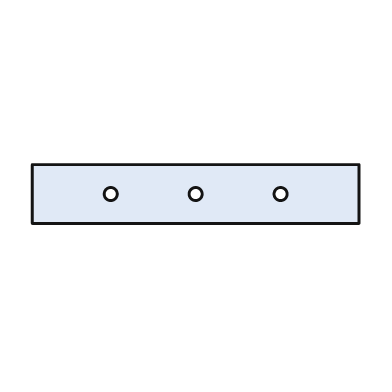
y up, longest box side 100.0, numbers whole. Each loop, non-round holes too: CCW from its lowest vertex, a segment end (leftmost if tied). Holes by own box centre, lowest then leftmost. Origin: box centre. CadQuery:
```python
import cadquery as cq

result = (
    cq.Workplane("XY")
    .moveTo(-50.0, -9.0)
    .lineTo(50.0, -9.0)
    .lineTo(50.0, 9.0)
    .lineTo(-50.0, 9.0)
    .close()
    .moveTo(-26.0, 0.0)
    .circle(2.0)
    .moveTo(0.0, 0.0)
    .circle(2.0)
    .moveTo(26.0, 0.0)
    .circle(2.0)
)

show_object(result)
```